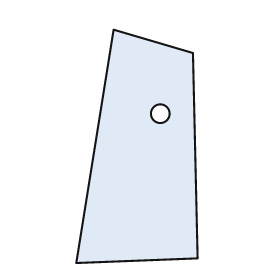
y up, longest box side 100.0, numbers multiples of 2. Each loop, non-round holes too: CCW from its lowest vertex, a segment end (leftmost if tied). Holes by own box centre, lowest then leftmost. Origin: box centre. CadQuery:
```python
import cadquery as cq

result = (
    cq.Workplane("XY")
    .moveTo(-26.0, -50.0)
    .lineTo(26.0, -48.0)
    .lineTo(24.0, 40.0)
    .lineTo(-10.0, 50.0)
    .close()
    .moveTo(10.0, 14.0)
    .circle(4.0)
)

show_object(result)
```